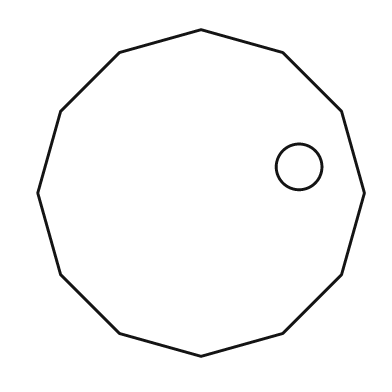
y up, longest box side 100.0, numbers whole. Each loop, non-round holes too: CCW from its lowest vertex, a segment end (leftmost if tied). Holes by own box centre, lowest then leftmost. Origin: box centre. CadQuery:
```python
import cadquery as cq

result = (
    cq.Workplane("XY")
    .moveTo(0.0, -50.0)
    .lineTo(25.0, -43.0)
    .lineTo(43.0, -25.0)
    .lineTo(50.0, 0.0)
    .lineTo(43.0, 25.0)
    .lineTo(25.0, 43.0)
    .lineTo(0.0, 50.0)
    .lineTo(-25.0, 43.0)
    .lineTo(-43.0, 25.0)
    .lineTo(-50.0, 0.0)
    .lineTo(-43.0, -25.0)
    .lineTo(-25.0, -43.0)
    .close()
    .moveTo(30.0, 8.0)
    .circle(7.0)
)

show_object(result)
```